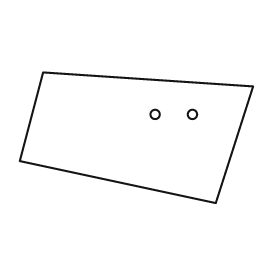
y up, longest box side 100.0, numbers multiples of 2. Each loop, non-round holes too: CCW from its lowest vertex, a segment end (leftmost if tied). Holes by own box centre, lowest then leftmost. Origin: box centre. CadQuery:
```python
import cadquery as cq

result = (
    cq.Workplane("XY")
    .moveTo(34.0, -28.0)
    .lineTo(50.0, 22.0)
    .lineTo(-40.0, 28.0)
    .lineTo(-50.0, -10.0)
    .close()
    .moveTo(8.0, 10.0)
    .circle(2.0)
    .moveTo(24.0, 10.0)
    .circle(2.0)
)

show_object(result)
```